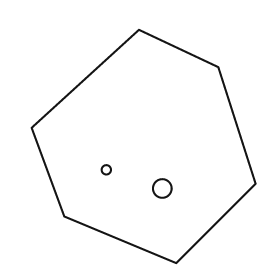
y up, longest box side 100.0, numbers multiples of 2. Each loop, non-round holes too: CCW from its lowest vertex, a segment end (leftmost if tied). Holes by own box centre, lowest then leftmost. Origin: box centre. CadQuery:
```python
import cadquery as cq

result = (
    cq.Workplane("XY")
    .moveTo(14.0, -50.0)
    .lineTo(48.0, -16.0)
    .lineTo(32.0, 34.0)
    .lineTo(-2.0, 50.0)
    .lineTo(-48.0, 8.0)
    .lineTo(-34.0, -30.0)
    .close()
    .moveTo(8.0, -18.0)
    .circle(4.0)
    .moveTo(-16.0, -10.0)
    .circle(2.0)
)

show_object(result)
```